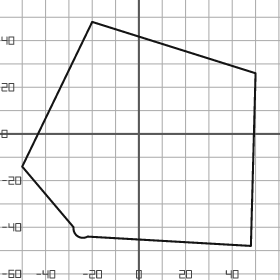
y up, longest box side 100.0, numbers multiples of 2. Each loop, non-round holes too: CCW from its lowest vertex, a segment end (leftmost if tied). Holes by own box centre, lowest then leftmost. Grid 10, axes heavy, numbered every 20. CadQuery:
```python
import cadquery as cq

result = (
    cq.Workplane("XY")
    .moveTo(48.0, -48.0)
    .lineTo(50.0, 26.0)
    .lineTo(-20.0, 48.0)
    .lineTo(-50.0, -14.0)
    .lineTo(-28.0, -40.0)
    .threePointArc((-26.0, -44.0), (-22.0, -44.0))
    .close()
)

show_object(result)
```